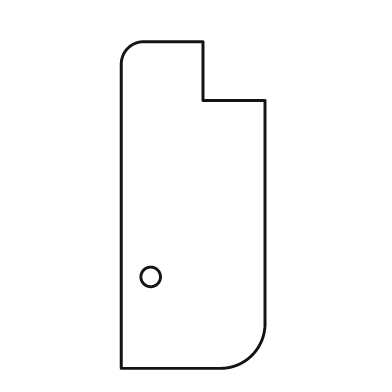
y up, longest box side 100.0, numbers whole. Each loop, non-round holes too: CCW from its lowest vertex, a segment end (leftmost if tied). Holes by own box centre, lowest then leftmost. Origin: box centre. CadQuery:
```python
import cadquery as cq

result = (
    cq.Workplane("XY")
    .moveTo(-22.0, -50.0)
    .lineTo(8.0, -50.0)
    .threePointArc((18.0, -46.0), (22.0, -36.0))
    .lineTo(22.0, 32.0)
    .lineTo(3.0, 32.0)
    .lineTo(3.0, 50.0)
    .lineTo(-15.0, 50.0)
    .threePointArc((-20.0, 48.0), (-22.0, 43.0))
    .close()
    .moveTo(-13.0, -22.0)
    .circle(3.0)
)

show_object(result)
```